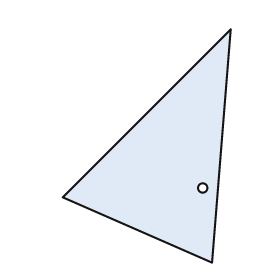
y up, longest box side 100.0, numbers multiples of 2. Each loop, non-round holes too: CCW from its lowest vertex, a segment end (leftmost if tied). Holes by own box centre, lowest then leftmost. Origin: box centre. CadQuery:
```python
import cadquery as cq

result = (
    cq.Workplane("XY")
    .moveTo(28.0, -50.0)
    .lineTo(36.0, 50.0)
    .lineTo(-36.0, -22.0)
    .close()
    .moveTo(24.0, -18.0)
    .circle(2.0)
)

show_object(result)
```